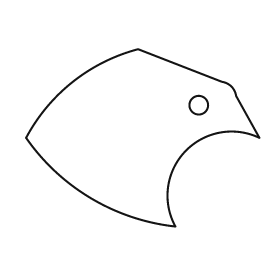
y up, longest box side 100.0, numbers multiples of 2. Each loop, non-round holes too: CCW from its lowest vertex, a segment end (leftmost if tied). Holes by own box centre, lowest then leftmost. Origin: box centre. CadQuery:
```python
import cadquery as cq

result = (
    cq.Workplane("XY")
    .moveTo(14.0, -38.0)
    .threePointArc((18.0, -6.0), (50.0, 0.0))
    .lineTo(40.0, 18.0)
    .threePointArc((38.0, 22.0), (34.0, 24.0))
    .lineTo(-2.0, 38.0)
    .threePointArc((-30.0, 24.0), (-50.0, 0.0))
    .threePointArc((-22.0, -26.0), (14.0, -38.0))
    .close()
    .moveTo(24.0, 14.0)
    .circle(4.0)
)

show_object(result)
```